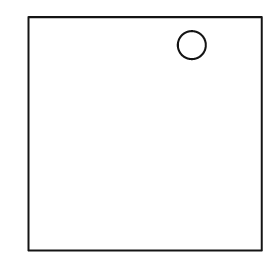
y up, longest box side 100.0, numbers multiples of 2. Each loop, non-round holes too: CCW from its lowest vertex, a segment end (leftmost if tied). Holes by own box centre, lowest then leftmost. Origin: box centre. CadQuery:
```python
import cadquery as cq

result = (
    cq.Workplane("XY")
    .moveTo(-50.0, -50.0)
    .lineTo(50.0, -50.0)
    .lineTo(50.0, 50.0)
    .lineTo(-50.0, 50.0)
    .close()
    .moveTo(20.0, 38.0)
    .circle(6.0)
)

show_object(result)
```